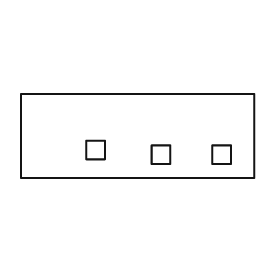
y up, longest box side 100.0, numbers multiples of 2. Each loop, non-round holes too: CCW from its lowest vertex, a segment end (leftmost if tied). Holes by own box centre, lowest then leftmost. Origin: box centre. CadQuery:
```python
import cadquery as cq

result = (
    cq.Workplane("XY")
    .moveTo(-50.0, -18.0)
    .lineTo(50.0, -18.0)
    .lineTo(50.0, 18.0)
    .lineTo(-50.0, 18.0)
    .close()
    .moveTo(6.0, -12.0)
    .lineTo(14.0, -12.0)
    .lineTo(14.0, -4.0)
    .lineTo(6.0, -4.0)
    .close()
    .moveTo(32.0, -12.0)
    .lineTo(40.0, -12.0)
    .lineTo(40.0, -4.0)
    .lineTo(32.0, -4.0)
    .close()
    .moveTo(-22.0, -10.0)
    .lineTo(-14.0, -10.0)
    .lineTo(-14.0, -2.0)
    .lineTo(-22.0, -2.0)
    .close()
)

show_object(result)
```